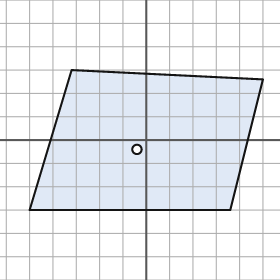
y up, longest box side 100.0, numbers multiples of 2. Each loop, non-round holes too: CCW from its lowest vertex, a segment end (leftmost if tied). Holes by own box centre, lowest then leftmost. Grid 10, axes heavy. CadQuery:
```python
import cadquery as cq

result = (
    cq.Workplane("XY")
    .moveTo(-50.0, -30.0)
    .lineTo(36.0, -30.0)
    .lineTo(50.0, 26.0)
    .lineTo(-32.0, 30.0)
    .close()
    .moveTo(-4.0, -4.0)
    .circle(2.0)
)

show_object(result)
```